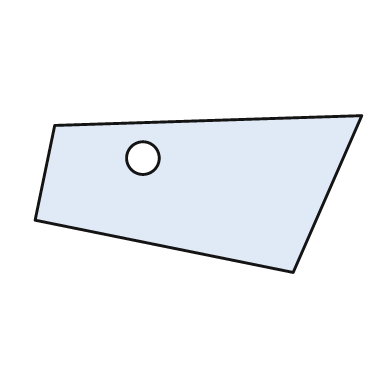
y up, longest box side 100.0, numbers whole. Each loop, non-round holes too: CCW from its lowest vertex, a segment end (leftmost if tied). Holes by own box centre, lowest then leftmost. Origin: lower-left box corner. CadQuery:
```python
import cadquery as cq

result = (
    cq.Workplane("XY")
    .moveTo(79.0, 0.0)
    .lineTo(100.0, 48.0)
    .lineTo(6.0, 45.0)
    .lineTo(0.0, 16.0)
    .close()
    .moveTo(33.0, 35.0)
    .circle(5.0)
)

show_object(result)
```